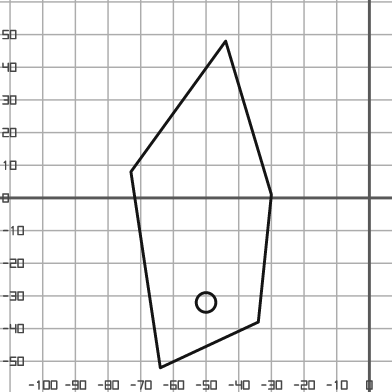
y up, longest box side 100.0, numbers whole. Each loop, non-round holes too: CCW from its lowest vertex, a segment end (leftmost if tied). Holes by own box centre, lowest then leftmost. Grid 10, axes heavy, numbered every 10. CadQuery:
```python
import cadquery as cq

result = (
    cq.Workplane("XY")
    .moveTo(-64.0, -52.0)
    .lineTo(-34.0, -38.0)
    .lineTo(-30.0, 1.0)
    .lineTo(-44.0, 48.0)
    .lineTo(-73.0, 8.0)
    .close()
    .moveTo(-50.0, -32.0)
    .circle(3.0)
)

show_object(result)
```